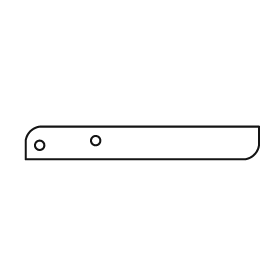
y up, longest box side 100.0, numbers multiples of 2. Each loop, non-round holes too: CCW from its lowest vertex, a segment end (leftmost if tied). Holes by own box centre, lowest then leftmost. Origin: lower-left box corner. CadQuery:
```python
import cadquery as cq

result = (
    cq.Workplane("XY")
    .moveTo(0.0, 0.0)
    .lineTo(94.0, 0.0)
    .threePointArc((98.0, 2.0), (100.0, 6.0))
    .lineTo(100.0, 14.0)
    .lineTo(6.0, 14.0)
    .threePointArc((2.0, 12.0), (0.0, 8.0))
    .close()
    .moveTo(6.0, 6.0)
    .circle(2.0)
    .moveTo(30.0, 8.0)
    .circle(2.0)
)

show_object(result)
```